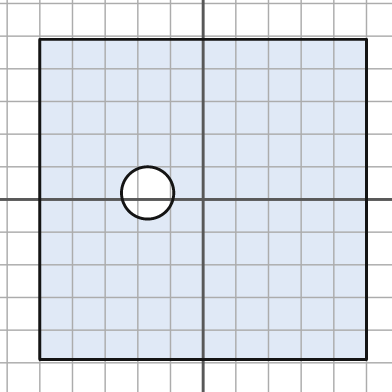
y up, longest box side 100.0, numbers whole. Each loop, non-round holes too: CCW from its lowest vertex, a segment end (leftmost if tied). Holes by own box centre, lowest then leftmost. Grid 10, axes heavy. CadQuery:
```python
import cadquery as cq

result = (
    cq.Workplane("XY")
    .moveTo(-50.0, -49.0)
    .lineTo(50.0, -49.0)
    .lineTo(50.0, 49.0)
    .lineTo(-50.0, 49.0)
    .close()
    .moveTo(-17.0, 2.0)
    .circle(8.0)
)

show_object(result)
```